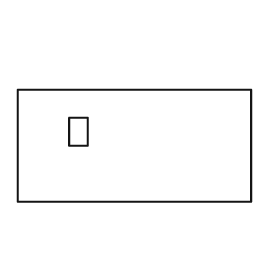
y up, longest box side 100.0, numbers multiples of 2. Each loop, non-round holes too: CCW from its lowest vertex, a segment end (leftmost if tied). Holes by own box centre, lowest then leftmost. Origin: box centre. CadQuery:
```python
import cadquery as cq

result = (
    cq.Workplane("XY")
    .moveTo(-50.0, -24.0)
    .lineTo(50.0, -24.0)
    .lineTo(50.0, 24.0)
    .lineTo(-50.0, 24.0)
    .close()
    .moveTo(-28.0, 0.0)
    .lineTo(-20.0, 0.0)
    .lineTo(-20.0, 12.0)
    .lineTo(-28.0, 12.0)
    .close()
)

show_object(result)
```